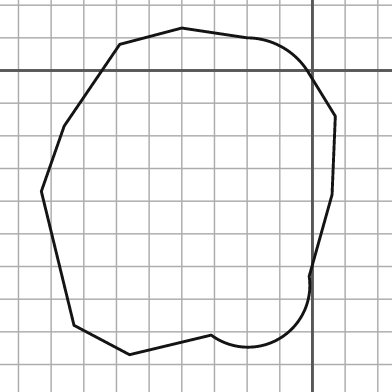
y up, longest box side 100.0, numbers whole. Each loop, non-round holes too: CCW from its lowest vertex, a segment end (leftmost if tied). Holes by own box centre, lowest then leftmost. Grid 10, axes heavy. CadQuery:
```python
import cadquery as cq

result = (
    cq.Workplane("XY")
    .moveTo(-56.0, -87.0)
    .lineTo(-31.0, -81.0)
    .threePointArc((-10.0, -82.0), (-1.0, -63.0))
    .lineTo(6.0, -38.0)
    .lineTo(7.0, -14.0)
    .lineTo(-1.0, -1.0)
    .threePointArc((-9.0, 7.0), (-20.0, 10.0))
    .lineTo(-40.0, 13.0)
    .lineTo(-59.0, 8.0)
    .lineTo(-76.0, -17.0)
    .lineTo(-83.0, -37.0)
    .lineTo(-73.0, -78.0)
    .close()
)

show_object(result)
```